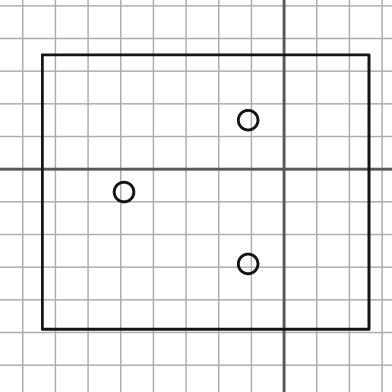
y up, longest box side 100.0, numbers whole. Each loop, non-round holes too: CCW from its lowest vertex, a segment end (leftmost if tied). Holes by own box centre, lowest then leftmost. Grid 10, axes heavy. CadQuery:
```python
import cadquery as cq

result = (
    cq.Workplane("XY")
    .moveTo(-74.0, -49.0)
    .lineTo(26.0, -49.0)
    .lineTo(26.0, 35.0)
    .lineTo(-74.0, 35.0)
    .close()
    .moveTo(-11.0, -29.0)
    .circle(3.0)
    .moveTo(-49.0, -7.0)
    .circle(3.0)
    .moveTo(-11.0, 15.0)
    .circle(3.0)
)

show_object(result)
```